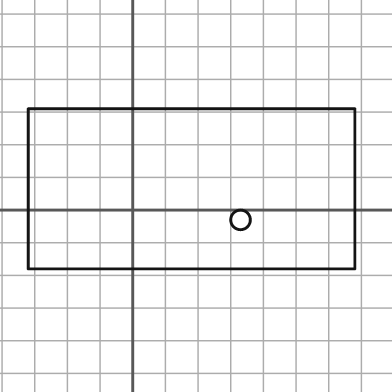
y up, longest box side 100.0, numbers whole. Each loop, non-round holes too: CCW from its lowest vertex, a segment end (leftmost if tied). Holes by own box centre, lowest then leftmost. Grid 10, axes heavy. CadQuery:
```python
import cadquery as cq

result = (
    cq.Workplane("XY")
    .moveTo(-32.0, -18.0)
    .lineTo(68.0, -18.0)
    .lineTo(68.0, 31.0)
    .lineTo(-32.0, 31.0)
    .close()
    .moveTo(33.0, -3.0)
    .circle(3.0)
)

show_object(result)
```